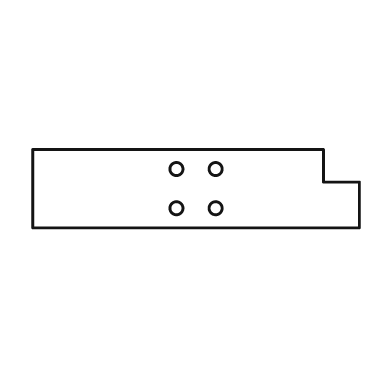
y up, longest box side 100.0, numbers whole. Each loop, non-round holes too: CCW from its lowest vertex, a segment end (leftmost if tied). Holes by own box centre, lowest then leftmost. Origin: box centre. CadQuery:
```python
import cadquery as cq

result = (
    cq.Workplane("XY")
    .moveTo(-50.0, -12.0)
    .lineTo(50.0, -12.0)
    .lineTo(50.0, 2.0)
    .lineTo(39.0, 2.0)
    .lineTo(39.0, 12.0)
    .lineTo(-50.0, 12.0)
    .close()
    .moveTo(-6.0, -6.0)
    .circle(2.0)
    .moveTo(6.0, -6.0)
    .circle(2.0)
    .moveTo(-6.0, 6.0)
    .circle(2.0)
    .moveTo(6.0, 6.0)
    .circle(2.0)
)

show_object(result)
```